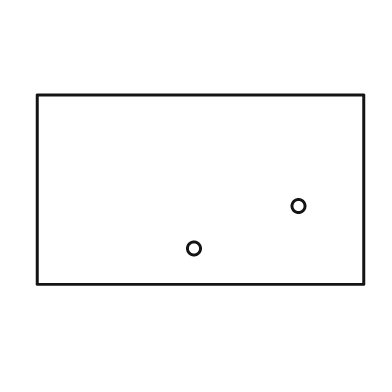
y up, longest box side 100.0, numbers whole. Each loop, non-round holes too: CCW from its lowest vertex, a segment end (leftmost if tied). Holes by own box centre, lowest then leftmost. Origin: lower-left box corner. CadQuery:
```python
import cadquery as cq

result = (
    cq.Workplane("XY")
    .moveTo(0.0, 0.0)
    .lineTo(100.0, 0.0)
    .lineTo(100.0, 58.0)
    .lineTo(0.0, 58.0)
    .close()
    .moveTo(48.0, 11.0)
    .circle(2.0)
    .moveTo(80.0, 24.0)
    .circle(2.0)
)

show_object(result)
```